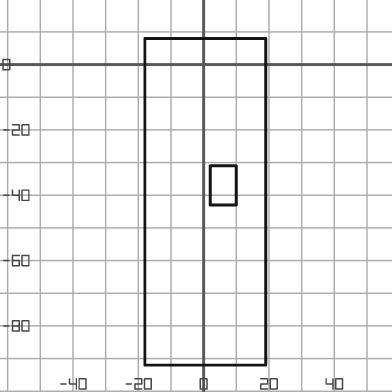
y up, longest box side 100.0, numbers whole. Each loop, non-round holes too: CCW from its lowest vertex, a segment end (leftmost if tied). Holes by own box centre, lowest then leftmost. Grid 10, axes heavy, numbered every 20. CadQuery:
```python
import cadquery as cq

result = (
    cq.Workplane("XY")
    .moveTo(-18.0, -92.0)
    .lineTo(19.0, -92.0)
    .lineTo(19.0, 8.0)
    .lineTo(-18.0, 8.0)
    .close()
    .moveTo(2.0, -43.0)
    .lineTo(10.0, -43.0)
    .lineTo(10.0, -31.0)
    .lineTo(2.0, -31.0)
    .close()
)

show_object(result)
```